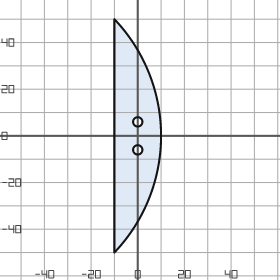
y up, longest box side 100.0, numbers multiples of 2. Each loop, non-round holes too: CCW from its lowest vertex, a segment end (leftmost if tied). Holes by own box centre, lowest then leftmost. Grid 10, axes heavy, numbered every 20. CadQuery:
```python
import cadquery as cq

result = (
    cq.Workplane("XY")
    .moveTo(-10.0, -50.0)
    .threePointArc((10.0, 0.0), (-10.0, 50.0))
    .close()
    .moveTo(0.0, -6.0)
    .circle(2.0)
    .moveTo(0.0, 6.0)
    .circle(2.0)
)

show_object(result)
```